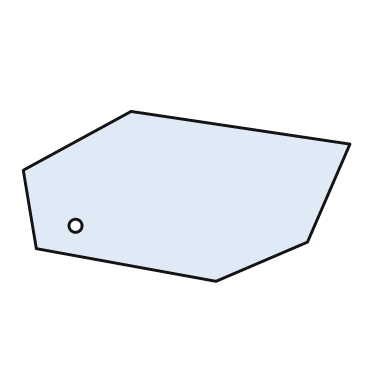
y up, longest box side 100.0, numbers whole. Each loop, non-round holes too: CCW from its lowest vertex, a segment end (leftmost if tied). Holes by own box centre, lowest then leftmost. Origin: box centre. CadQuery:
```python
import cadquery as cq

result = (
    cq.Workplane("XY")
    .moveTo(9.0, -26.0)
    .lineTo(37.0, -14.0)
    .lineTo(50.0, 16.0)
    .lineTo(-17.0, 26.0)
    .lineTo(-50.0, 8.0)
    .lineTo(-46.0, -16.0)
    .close()
    .moveTo(-34.0, -9.0)
    .circle(2.0)
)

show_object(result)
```